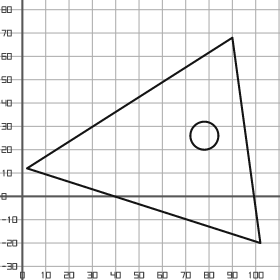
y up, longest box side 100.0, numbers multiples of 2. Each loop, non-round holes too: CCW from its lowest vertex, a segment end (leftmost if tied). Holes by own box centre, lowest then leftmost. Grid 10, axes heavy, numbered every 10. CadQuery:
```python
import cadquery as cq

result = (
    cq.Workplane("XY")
    .moveTo(102.0, -20.0)
    .lineTo(90.0, 68.0)
    .lineTo(2.0, 12.0)
    .close()
    .moveTo(78.0, 26.0)
    .circle(6.0)
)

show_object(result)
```